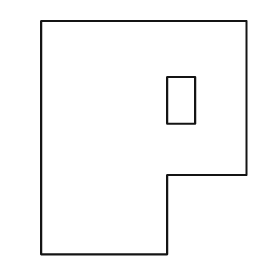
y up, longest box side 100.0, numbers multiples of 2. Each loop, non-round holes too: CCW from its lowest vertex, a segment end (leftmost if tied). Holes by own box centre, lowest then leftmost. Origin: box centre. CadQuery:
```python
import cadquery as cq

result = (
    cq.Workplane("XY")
    .moveTo(-44.0, -50.0)
    .lineTo(10.0, -50.0)
    .lineTo(10.0, -16.0)
    .lineTo(44.0, -16.0)
    .lineTo(44.0, 50.0)
    .lineTo(-44.0, 50.0)
    .close()
    .moveTo(10.0, 6.0)
    .lineTo(22.0, 6.0)
    .lineTo(22.0, 26.0)
    .lineTo(10.0, 26.0)
    .close()
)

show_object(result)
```